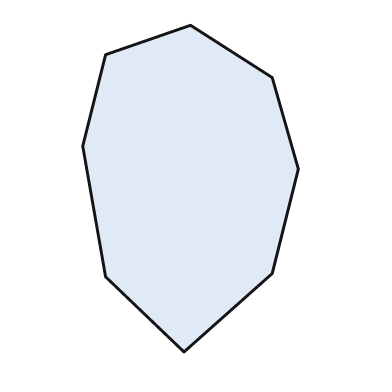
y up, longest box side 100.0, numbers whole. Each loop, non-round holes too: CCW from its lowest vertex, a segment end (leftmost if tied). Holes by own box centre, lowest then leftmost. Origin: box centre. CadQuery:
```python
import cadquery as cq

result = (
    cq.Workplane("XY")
    .moveTo(-2.0, -50.0)
    .lineTo(25.0, -26.0)
    .lineTo(33.0, 6.0)
    .lineTo(25.0, 34.0)
    .lineTo(0.0, 50.0)
    .lineTo(-26.0, 41.0)
    .lineTo(-33.0, 13.0)
    .lineTo(-26.0, -27.0)
    .close()
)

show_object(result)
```